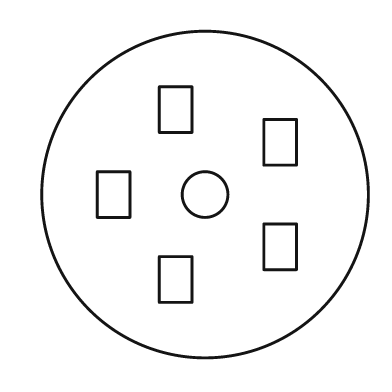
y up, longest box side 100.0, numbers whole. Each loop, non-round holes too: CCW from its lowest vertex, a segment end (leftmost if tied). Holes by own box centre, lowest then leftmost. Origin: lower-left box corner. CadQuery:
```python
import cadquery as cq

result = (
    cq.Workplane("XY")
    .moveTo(50.0, 50.0)
    .circle(50.0)
    .moveTo(36.0, 17.0)
    .lineTo(46.0, 17.0)
    .lineTo(46.0, 31.0)
    .lineTo(36.0, 31.0)
    .close()
    .moveTo(68.0, 27.0)
    .lineTo(78.0, 27.0)
    .lineTo(78.0, 41.0)
    .lineTo(68.0, 41.0)
    .close()
    .moveTo(17.0, 43.0)
    .lineTo(27.0, 43.0)
    .lineTo(27.0, 57.0)
    .lineTo(17.0, 57.0)
    .close()
    .moveTo(50.0, 50.0)
    .circle(7.0)
    .moveTo(68.0, 59.0)
    .lineTo(78.0, 59.0)
    .lineTo(78.0, 73.0)
    .lineTo(68.0, 73.0)
    .close()
    .moveTo(36.0, 69.0)
    .lineTo(46.0, 69.0)
    .lineTo(46.0, 83.0)
    .lineTo(36.0, 83.0)
    .close()
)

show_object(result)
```